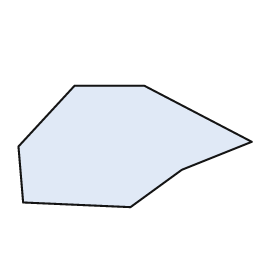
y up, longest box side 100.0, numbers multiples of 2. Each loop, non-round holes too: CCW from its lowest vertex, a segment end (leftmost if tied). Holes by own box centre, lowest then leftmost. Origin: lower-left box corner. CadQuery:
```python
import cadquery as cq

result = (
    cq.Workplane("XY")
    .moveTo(48.0, 0.0)
    .lineTo(70.0, 16.0)
    .lineTo(100.0, 28.0)
    .lineTo(54.0, 52.0)
    .lineTo(24.0, 52.0)
    .lineTo(0.0, 26.0)
    .lineTo(2.0, 2.0)
    .close()
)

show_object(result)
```